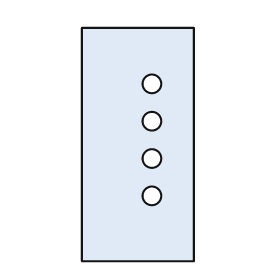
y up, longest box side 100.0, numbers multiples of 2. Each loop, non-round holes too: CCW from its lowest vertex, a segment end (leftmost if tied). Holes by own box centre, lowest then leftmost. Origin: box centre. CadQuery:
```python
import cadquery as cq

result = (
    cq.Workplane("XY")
    .moveTo(-24.0, -50.0)
    .lineTo(24.0, -50.0)
    .lineTo(24.0, 50.0)
    .lineTo(-24.0, 50.0)
    .close()
    .moveTo(6.0, -22.0)
    .circle(4.0)
    .moveTo(6.0, -6.0)
    .circle(4.0)
    .moveTo(6.0, 10.0)
    .circle(4.0)
    .moveTo(6.0, 26.0)
    .circle(4.0)
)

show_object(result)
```